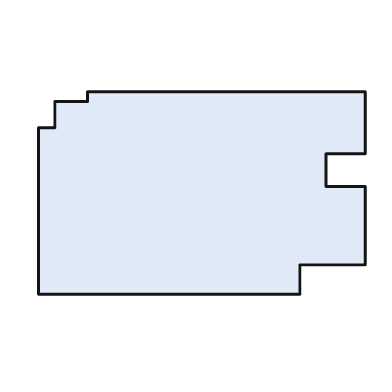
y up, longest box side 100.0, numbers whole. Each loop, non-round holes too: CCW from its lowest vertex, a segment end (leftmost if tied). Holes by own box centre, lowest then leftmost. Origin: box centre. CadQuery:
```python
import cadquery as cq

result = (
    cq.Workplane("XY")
    .moveTo(-50.0, -31.0)
    .lineTo(30.0, -31.0)
    .lineTo(30.0, -22.0)
    .lineTo(50.0, -22.0)
    .lineTo(50.0, 2.0)
    .lineTo(38.0, 2.0)
    .lineTo(38.0, 12.0)
    .lineTo(50.0, 12.0)
    .lineTo(50.0, 31.0)
    .lineTo(-35.0, 31.0)
    .lineTo(-35.0, 28.0)
    .lineTo(-45.0, 28.0)
    .lineTo(-45.0, 20.0)
    .lineTo(-50.0, 20.0)
    .close()
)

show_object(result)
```